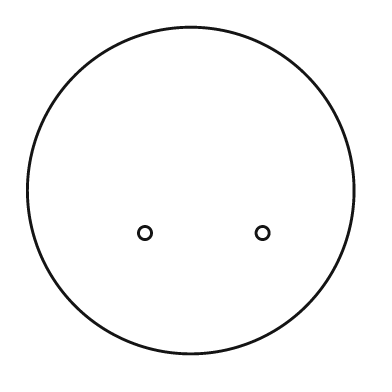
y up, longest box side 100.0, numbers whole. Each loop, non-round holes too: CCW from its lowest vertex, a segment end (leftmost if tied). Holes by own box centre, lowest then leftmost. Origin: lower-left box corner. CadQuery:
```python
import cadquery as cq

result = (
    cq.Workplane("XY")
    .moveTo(50.0, 50.0)
    .circle(50.0)
    .moveTo(36.0, 37.0)
    .circle(2.0)
    .moveTo(72.0, 37.0)
    .circle(2.0)
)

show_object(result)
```